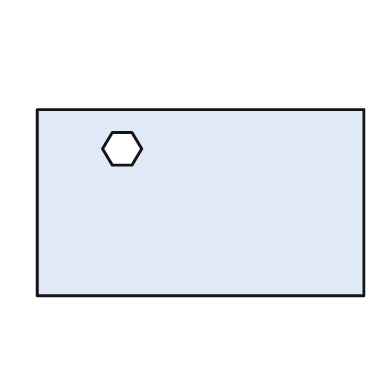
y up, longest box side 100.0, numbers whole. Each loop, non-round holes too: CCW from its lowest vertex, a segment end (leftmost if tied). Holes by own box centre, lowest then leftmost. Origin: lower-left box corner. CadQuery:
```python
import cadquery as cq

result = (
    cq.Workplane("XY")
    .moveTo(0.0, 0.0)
    .lineTo(100.0, 0.0)
    .lineTo(100.0, 57.0)
    .lineTo(0.0, 57.0)
    .close()
    .moveTo(23.0, 40.0)
    .lineTo(29.0, 40.0)
    .lineTo(32.0, 45.0)
    .lineTo(29.0, 50.0)
    .lineTo(23.0, 50.0)
    .lineTo(20.0, 45.0)
    .close()
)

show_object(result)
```